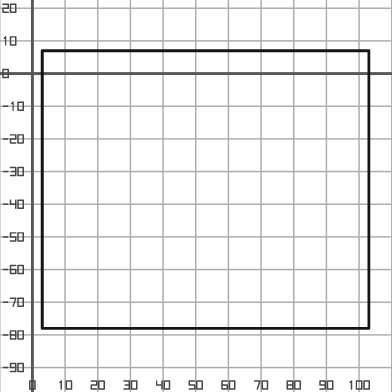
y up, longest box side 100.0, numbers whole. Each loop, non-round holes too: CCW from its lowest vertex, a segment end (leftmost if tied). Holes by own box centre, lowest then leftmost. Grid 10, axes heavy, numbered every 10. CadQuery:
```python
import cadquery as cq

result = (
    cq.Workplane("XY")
    .moveTo(3.0, -78.0)
    .lineTo(103.0, -78.0)
    .lineTo(103.0, 7.0)
    .lineTo(3.0, 7.0)
    .close()
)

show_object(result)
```